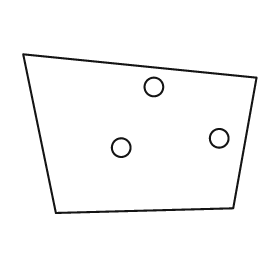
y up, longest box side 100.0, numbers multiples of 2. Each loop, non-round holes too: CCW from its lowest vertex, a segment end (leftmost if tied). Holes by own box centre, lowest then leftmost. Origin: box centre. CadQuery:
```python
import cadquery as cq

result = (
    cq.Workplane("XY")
    .moveTo(-36.0, -34.0)
    .lineTo(40.0, -32.0)
    .lineTo(50.0, 24.0)
    .lineTo(-50.0, 34.0)
    .close()
    .moveTo(-8.0, -6.0)
    .circle(4.0)
    .moveTo(34.0, -2.0)
    .circle(4.0)
    .moveTo(6.0, 20.0)
    .circle(4.0)
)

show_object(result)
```